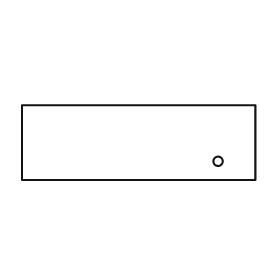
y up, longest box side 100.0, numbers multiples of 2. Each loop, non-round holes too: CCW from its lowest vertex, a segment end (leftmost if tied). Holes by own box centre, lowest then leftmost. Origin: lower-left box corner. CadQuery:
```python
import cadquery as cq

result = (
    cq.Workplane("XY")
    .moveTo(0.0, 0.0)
    .lineTo(100.0, 0.0)
    .lineTo(100.0, 32.0)
    .lineTo(0.0, 32.0)
    .close()
    .moveTo(84.0, 8.0)
    .circle(2.0)
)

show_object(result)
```